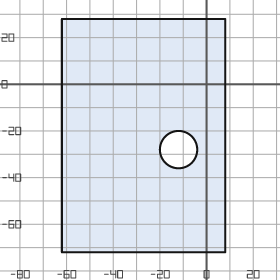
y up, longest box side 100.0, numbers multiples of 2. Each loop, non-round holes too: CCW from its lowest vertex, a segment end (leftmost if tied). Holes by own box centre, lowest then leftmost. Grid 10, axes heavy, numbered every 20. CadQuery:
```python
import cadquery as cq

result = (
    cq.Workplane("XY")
    .moveTo(-62.0, -72.0)
    .lineTo(8.0, -72.0)
    .lineTo(8.0, 28.0)
    .lineTo(-62.0, 28.0)
    .close()
    .moveTo(-12.0, -28.0)
    .circle(8.0)
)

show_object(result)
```